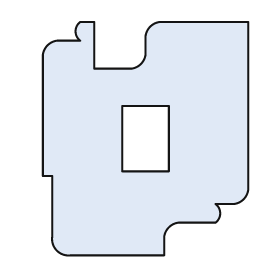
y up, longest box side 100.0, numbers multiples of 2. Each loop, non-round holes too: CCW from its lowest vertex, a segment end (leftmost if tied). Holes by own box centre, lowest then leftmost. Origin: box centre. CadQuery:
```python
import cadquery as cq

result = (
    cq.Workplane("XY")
    .moveTo(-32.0, -50.0)
    .lineTo(8.0, -50.0)
    .lineTo(8.0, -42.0)
    .threePointArc((10.0, -38.0), (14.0, -36.0))
    .lineTo(30.0, -36.0)
    .threePointArc((32.0, -32.0), (30.0, -28.0))
    .lineTo(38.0, -28.0)
    .threePointArc((42.0, -26.0), (44.0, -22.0))
    .lineTo(44.0, 50.0)
    .lineTo(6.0, 50.0)
    .threePointArc((2.0, 48.0), (0.0, 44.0))
    .lineTo(0.0, 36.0)
    .threePointArc((-2.0, 32.0), (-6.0, 30.0))
    .lineTo(-22.0, 30.0)
    .lineTo(-22.0, 50.0)
    .lineTo(-28.0, 50.0)
    .threePointArc((-30.0, 46.0), (-28.0, 42.0))
    .lineTo(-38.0, 42.0)
    .threePointArc((-42.0, 40.0), (-44.0, 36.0))
    .lineTo(-44.0, -16.0)
    .lineTo(-40.0, -16.0)
    .lineTo(-40.0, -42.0)
    .threePointArc((-38.0, -48.0), (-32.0, -50.0))
    .close()
    .moveTo(-10.0, -14.0)
    .lineTo(10.0, -14.0)
    .lineTo(10.0, 14.0)
    .lineTo(-10.0, 14.0)
    .close()
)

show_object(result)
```